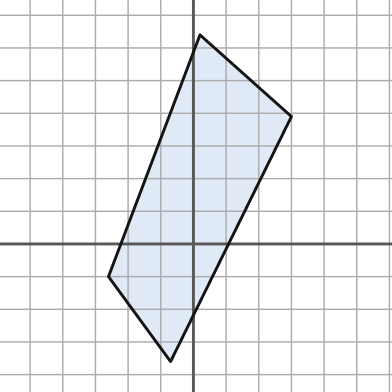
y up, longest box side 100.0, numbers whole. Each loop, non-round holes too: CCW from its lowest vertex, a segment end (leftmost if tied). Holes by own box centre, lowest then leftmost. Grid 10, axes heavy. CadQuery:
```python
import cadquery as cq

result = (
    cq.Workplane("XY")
    .moveTo(-7.0, -36.0)
    .lineTo(30.0, 39.0)
    .lineTo(2.0, 64.0)
    .lineTo(-26.0, -10.0)
    .close()
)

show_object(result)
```